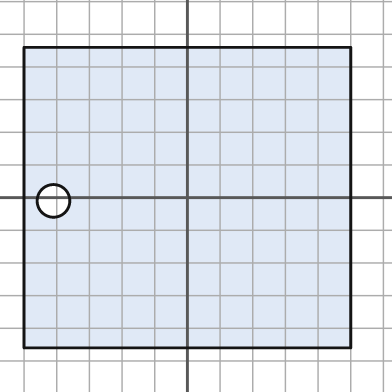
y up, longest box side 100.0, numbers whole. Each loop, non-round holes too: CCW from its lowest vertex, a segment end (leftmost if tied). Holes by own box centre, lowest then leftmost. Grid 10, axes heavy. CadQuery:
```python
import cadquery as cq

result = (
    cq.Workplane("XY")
    .moveTo(-50.0, -46.0)
    .lineTo(50.0, -46.0)
    .lineTo(50.0, 46.0)
    .lineTo(-50.0, 46.0)
    .close()
    .moveTo(-41.0, -1.0)
    .circle(5.0)
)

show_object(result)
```